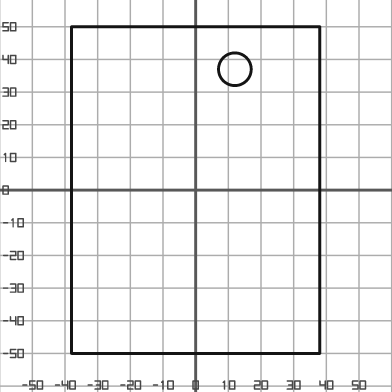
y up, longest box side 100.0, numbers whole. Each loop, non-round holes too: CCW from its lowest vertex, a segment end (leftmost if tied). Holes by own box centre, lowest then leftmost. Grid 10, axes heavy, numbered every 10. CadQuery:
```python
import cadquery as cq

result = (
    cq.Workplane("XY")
    .moveTo(-38.0, -50.0)
    .lineTo(38.0, -50.0)
    .lineTo(38.0, 50.0)
    .lineTo(-38.0, 50.0)
    .close()
    .moveTo(12.0, 37.0)
    .circle(5.0)
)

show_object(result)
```